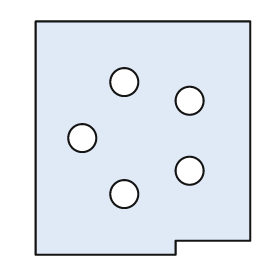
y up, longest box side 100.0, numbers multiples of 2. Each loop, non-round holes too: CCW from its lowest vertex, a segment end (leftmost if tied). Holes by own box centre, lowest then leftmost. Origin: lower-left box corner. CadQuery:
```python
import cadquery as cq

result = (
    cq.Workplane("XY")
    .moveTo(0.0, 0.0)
    .lineTo(60.0, 0.0)
    .lineTo(60.0, 6.0)
    .lineTo(92.0, 6.0)
    .lineTo(92.0, 100.0)
    .lineTo(0.0, 100.0)
    .close()
    .moveTo(38.0, 26.0)
    .circle(6.0)
    .moveTo(66.0, 36.0)
    .circle(6.0)
    .moveTo(20.0, 50.0)
    .circle(6.0)
    .moveTo(66.0, 66.0)
    .circle(6.0)
    .moveTo(38.0, 74.0)
    .circle(6.0)
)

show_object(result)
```